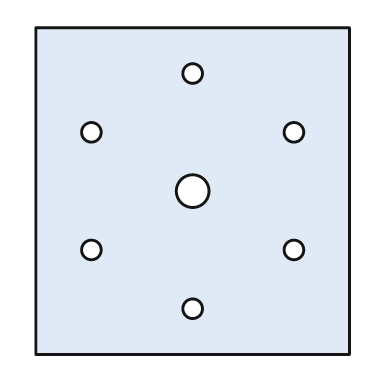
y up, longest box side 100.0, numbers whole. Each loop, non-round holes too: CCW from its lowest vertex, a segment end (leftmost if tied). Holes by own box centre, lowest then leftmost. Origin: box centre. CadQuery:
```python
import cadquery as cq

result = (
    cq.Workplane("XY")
    .moveTo(-48.0, -50.0)
    .lineTo(48.0, -50.0)
    .lineTo(48.0, 50.0)
    .lineTo(-48.0, 50.0)
    .close()
    .moveTo(0.0, -36.0)
    .circle(3.0)
    .moveTo(-31.0, -18.0)
    .circle(3.0)
    .moveTo(31.0, -18.0)
    .circle(3.0)
    .moveTo(0.0, 0.0)
    .circle(5.0)
    .moveTo(-31.0, 18.0)
    .circle(3.0)
    .moveTo(31.0, 18.0)
    .circle(3.0)
    .moveTo(0.0, 36.0)
    .circle(3.0)
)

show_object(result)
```